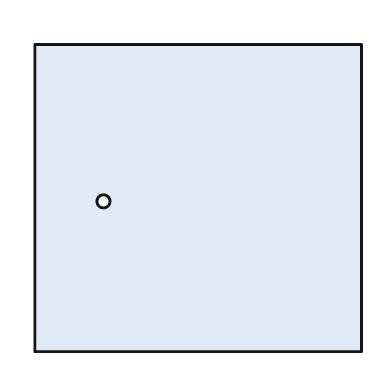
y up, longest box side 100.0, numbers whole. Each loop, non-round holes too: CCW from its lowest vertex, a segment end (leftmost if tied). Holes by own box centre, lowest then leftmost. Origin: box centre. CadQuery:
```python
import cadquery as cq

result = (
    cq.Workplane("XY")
    .moveTo(-50.0, -47.0)
    .lineTo(50.0, -47.0)
    .lineTo(50.0, 47.0)
    .lineTo(-50.0, 47.0)
    .close()
    .moveTo(-29.0, -1.0)
    .circle(2.0)
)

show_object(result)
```